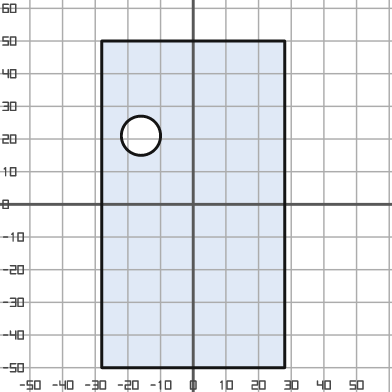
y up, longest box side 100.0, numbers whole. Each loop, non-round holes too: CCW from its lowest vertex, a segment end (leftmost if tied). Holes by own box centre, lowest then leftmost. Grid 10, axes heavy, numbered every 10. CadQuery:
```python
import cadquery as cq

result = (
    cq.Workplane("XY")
    .moveTo(-28.0, -50.0)
    .lineTo(28.0, -50.0)
    .lineTo(28.0, 50.0)
    .lineTo(-28.0, 50.0)
    .close()
    .moveTo(-16.0, 21.0)
    .circle(6.0)
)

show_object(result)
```